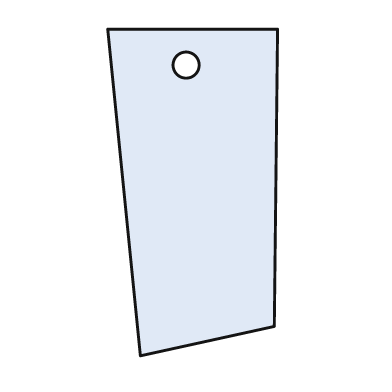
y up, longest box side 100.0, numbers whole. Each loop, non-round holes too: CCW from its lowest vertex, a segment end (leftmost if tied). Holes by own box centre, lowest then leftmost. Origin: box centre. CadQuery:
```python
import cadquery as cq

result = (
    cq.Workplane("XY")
    .moveTo(-16.0, -50.0)
    .lineTo(25.0, -41.0)
    .lineTo(26.0, 50.0)
    .lineTo(-26.0, 50.0)
    .close()
    .moveTo(-2.0, 39.0)
    .circle(4.0)
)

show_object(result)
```